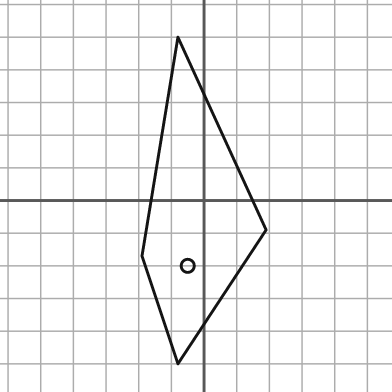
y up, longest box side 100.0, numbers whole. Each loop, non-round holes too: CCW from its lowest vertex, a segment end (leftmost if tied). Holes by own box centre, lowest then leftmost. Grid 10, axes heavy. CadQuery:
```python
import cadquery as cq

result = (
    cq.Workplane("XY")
    .moveTo(-8.0, -50.0)
    .lineTo(19.0, -9.0)
    .lineTo(-8.0, 50.0)
    .lineTo(-19.0, -17.0)
    .close()
    .moveTo(-5.0, -20.0)
    .circle(2.0)
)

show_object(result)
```